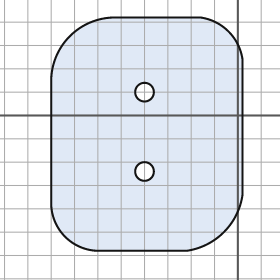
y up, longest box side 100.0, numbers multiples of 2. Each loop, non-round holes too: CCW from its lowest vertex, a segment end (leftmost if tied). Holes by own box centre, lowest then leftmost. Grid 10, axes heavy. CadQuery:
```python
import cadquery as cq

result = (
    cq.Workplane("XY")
    .moveTo(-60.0, -58.0)
    .lineTo(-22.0, -58.0)
    .threePointArc((-6.0, -50.0), (2.0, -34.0))
    .lineTo(2.0, 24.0)
    .threePointArc((-4.0, 36.0), (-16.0, 42.0))
    .lineTo(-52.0, 42.0)
    .threePointArc((-72.0, 34.0), (-80.0, 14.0))
    .lineTo(-80.0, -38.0)
    .threePointArc((-74.0, -52.0), (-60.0, -58.0))
    .close()
    .moveTo(-40.0, -24.0)
    .circle(4.0)
    .moveTo(-40.0, 10.0)
    .circle(4.0)
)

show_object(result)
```